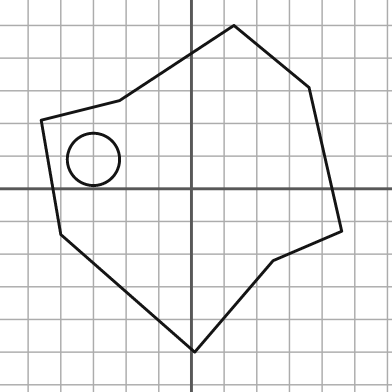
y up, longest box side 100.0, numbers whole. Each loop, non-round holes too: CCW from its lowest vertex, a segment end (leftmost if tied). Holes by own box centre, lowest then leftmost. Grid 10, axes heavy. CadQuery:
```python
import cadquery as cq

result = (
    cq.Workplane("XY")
    .moveTo(1.0, -50.0)
    .lineTo(25.0, -22.0)
    .lineTo(46.0, -13.0)
    .lineTo(36.0, 31.0)
    .lineTo(13.0, 50.0)
    .lineTo(-22.0, 27.0)
    .lineTo(-46.0, 21.0)
    .lineTo(-40.0, -14.0)
    .close()
    .moveTo(-30.0, 9.0)
    .circle(8.0)
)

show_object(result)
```